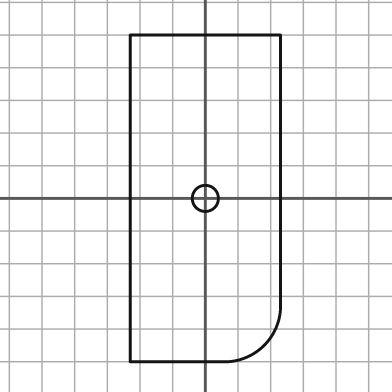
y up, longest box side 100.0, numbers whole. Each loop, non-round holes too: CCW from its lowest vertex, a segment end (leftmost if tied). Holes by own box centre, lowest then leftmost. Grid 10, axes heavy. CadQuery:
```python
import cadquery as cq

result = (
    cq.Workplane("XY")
    .moveTo(-23.0, -50.0)
    .lineTo(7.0, -50.0)
    .threePointArc((18.0, -45.0), (23.0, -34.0))
    .lineTo(23.0, 50.0)
    .lineTo(-23.0, 50.0)
    .close()
    .moveTo(0.0, 0.0)
    .circle(4.0)
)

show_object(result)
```